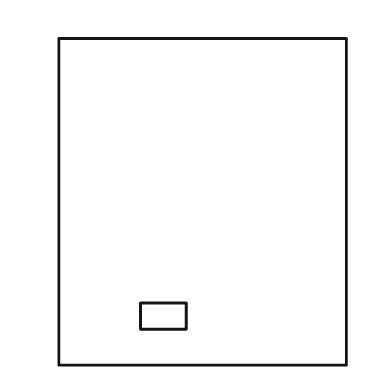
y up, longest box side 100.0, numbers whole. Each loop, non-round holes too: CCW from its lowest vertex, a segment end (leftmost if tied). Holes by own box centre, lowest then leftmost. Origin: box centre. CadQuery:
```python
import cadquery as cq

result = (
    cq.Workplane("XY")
    .moveTo(-44.0, -50.0)
    .lineTo(44.0, -50.0)
    .lineTo(44.0, 50.0)
    .lineTo(-44.0, 50.0)
    .close()
    .moveTo(-19.0, -39.0)
    .lineTo(-5.0, -39.0)
    .lineTo(-5.0, -31.0)
    .lineTo(-19.0, -31.0)
    .close()
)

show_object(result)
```